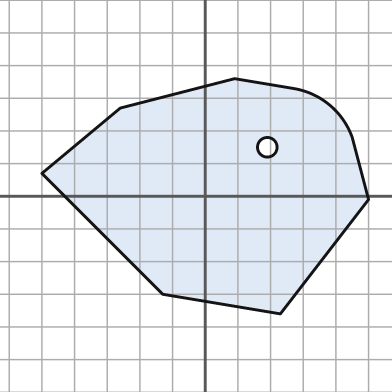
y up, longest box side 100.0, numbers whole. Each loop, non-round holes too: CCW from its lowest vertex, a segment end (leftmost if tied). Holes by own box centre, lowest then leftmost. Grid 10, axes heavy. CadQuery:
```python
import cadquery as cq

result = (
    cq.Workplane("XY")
    .moveTo(23.0, -36.0)
    .lineTo(50.0, -1.0)
    .lineTo(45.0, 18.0)
    .threePointArc((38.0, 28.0), (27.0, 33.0))
    .lineTo(9.0, 36.0)
    .lineTo(-26.0, 27.0)
    .lineTo(-50.0, 7.0)
    .lineTo(-13.0, -30.0)
    .close()
    .moveTo(19.0, 15.0)
    .circle(3.0)
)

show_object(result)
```